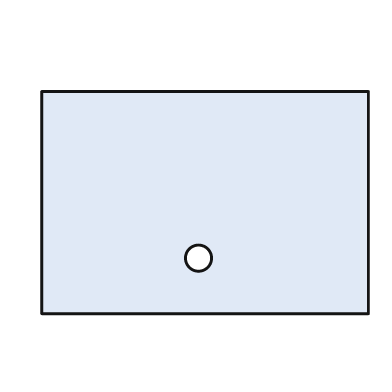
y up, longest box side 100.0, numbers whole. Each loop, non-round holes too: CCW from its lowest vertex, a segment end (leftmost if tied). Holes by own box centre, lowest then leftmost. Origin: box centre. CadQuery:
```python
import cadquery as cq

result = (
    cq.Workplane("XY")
    .moveTo(-50.0, -34.0)
    .lineTo(50.0, -34.0)
    .lineTo(50.0, 34.0)
    .lineTo(-50.0, 34.0)
    .close()
    .moveTo(-2.0, -17.0)
    .circle(4.0)
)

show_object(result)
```